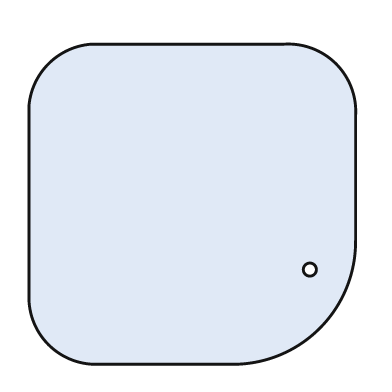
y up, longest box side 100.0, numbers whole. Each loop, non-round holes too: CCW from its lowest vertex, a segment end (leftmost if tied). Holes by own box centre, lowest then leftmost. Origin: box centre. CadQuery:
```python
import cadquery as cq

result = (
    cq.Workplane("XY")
    .moveTo(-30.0, -49.0)
    .lineTo(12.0, -49.0)
    .threePointArc((39.0, -38.0), (50.0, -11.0))
    .lineTo(50.0, 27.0)
    .threePointArc((44.0, 43.0), (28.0, 49.0))
    .lineTo(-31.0, 49.0)
    .threePointArc((-44.0, 43.0), (-50.0, 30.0))
    .lineTo(-50.0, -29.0)
    .threePointArc((-44.0, -43.0), (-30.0, -49.0))
    .close()
    .moveTo(36.0, -20.0)
    .circle(2.0)
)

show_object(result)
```